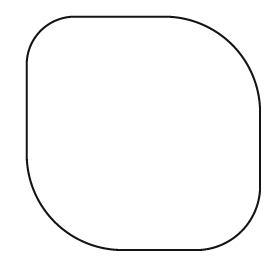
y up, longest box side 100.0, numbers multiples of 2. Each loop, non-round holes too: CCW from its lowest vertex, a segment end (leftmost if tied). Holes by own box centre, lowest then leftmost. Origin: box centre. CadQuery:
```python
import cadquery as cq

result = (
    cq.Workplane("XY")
    .moveTo(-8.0, -50.0)
    .lineTo(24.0, -50.0)
    .threePointArc((42.0, -42.0), (50.0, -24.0))
    .lineTo(50.0, 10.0)
    .threePointArc((38.0, 38.0), (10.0, 50.0))
    .lineTo(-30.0, 50.0)
    .threePointArc((-44.0, 44.0), (-50.0, 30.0))
    .lineTo(-50.0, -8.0)
    .threePointArc((-38.0, -38.0), (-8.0, -50.0))
    .close()
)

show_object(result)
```